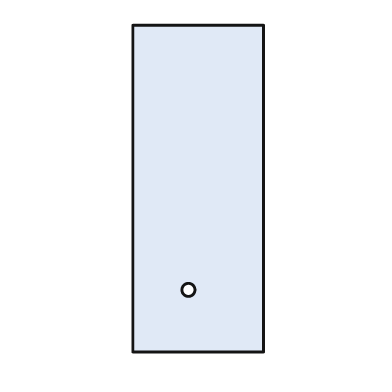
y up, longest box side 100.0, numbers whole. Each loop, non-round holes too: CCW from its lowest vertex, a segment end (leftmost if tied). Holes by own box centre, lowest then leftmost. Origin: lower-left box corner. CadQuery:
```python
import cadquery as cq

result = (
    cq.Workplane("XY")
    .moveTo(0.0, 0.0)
    .lineTo(40.0, 0.0)
    .lineTo(40.0, 100.0)
    .lineTo(0.0, 100.0)
    .close()
    .moveTo(17.0, 19.0)
    .circle(2.0)
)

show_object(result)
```